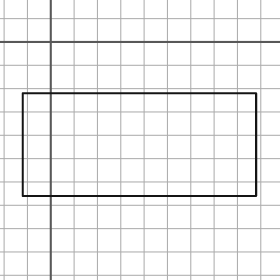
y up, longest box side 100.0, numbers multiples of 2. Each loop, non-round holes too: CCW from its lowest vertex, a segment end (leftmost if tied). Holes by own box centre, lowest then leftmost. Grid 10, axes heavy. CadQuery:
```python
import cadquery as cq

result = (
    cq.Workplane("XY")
    .moveTo(-12.0, -66.0)
    .lineTo(88.0, -66.0)
    .lineTo(88.0, -22.0)
    .lineTo(-12.0, -22.0)
    .close()
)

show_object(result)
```